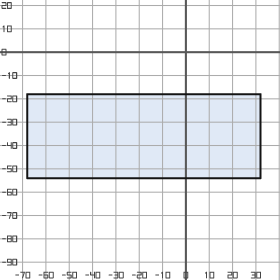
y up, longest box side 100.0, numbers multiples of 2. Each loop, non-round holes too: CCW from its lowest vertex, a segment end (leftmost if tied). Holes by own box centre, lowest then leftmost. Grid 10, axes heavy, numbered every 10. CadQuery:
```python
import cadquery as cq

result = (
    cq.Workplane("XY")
    .moveTo(-68.0, -54.0)
    .lineTo(32.0, -54.0)
    .lineTo(32.0, -18.0)
    .lineTo(-68.0, -18.0)
    .close()
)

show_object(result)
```